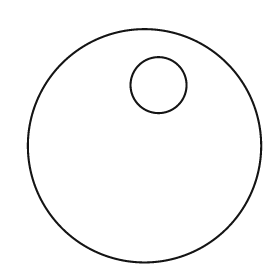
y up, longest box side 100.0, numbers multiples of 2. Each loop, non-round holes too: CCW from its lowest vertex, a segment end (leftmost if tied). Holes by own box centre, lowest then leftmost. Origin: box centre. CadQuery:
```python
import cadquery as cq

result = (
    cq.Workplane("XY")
    .moveTo(0.0, 0.0)
    .circle(50.0)
    .moveTo(6.0, 26.0)
    .circle(12.0)
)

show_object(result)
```